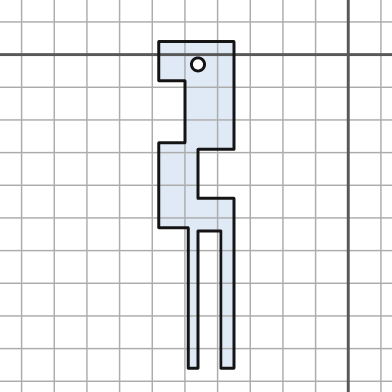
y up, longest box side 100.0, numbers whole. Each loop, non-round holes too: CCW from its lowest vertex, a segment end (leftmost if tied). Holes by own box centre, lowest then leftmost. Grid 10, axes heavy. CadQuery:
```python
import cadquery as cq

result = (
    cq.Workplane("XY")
    .moveTo(-49.0, -96.0)
    .lineTo(-46.0, -96.0)
    .lineTo(-46.0, -54.0)
    .lineTo(-39.0, -54.0)
    .lineTo(-39.0, -96.0)
    .lineTo(-35.0, -96.0)
    .lineTo(-35.0, -44.0)
    .lineTo(-46.0, -44.0)
    .lineTo(-46.0, -29.0)
    .lineTo(-35.0, -29.0)
    .lineTo(-35.0, 4.0)
    .lineTo(-58.0, 4.0)
    .lineTo(-58.0, -8.0)
    .lineTo(-50.0, -8.0)
    .lineTo(-50.0, -27.0)
    .lineTo(-58.0, -27.0)
    .lineTo(-58.0, -53.0)
    .lineTo(-49.0, -53.0)
    .close()
    .moveTo(-46.0, -3.0)
    .circle(2.0)
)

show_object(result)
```